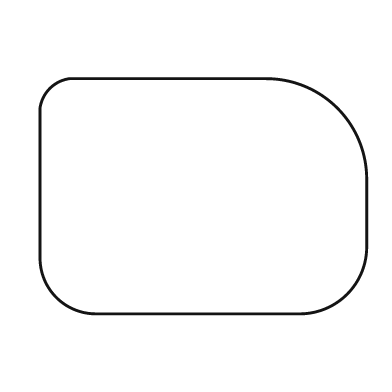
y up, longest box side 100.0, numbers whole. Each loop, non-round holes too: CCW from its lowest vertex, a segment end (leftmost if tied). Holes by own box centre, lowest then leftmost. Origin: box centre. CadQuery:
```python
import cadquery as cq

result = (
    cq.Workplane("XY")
    .moveTo(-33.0, -36.0)
    .lineTo(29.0, -36.0)
    .threePointArc((44.0, -30.0), (50.0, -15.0))
    .lineTo(50.0, 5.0)
    .threePointArc((41.0, 27.0), (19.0, 36.0))
    .lineTo(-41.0, 36.0)
    .threePointArc((-47.0, 33.0), (-50.0, 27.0))
    .lineTo(-50.0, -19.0)
    .threePointArc((-45.0, -31.0), (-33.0, -36.0))
    .close()
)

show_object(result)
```